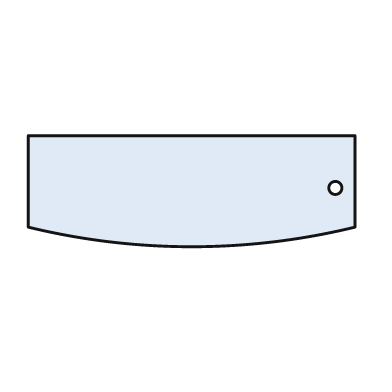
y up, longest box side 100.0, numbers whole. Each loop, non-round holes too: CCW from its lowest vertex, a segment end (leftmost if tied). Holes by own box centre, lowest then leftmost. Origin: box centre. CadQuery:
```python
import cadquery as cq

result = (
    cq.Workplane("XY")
    .moveTo(-50.0, -11.0)
    .threePointArc((0.0, -17.0), (50.0, -11.0))
    .lineTo(50.0, 17.0)
    .lineTo(-50.0, 17.0)
    .close()
    .moveTo(44.0, 1.0)
    .circle(2.0)
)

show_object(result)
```